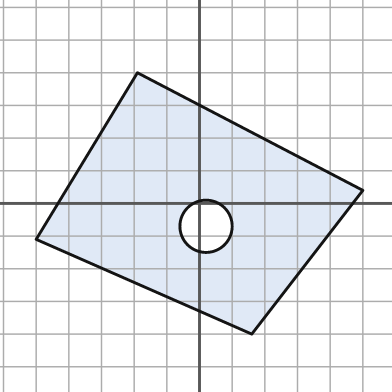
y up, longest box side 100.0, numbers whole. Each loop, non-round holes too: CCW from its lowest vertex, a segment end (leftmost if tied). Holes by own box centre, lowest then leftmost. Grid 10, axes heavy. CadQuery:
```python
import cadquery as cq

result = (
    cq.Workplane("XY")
    .moveTo(16.0, -40.0)
    .lineTo(50.0, 4.0)
    .lineTo(-19.0, 40.0)
    .lineTo(-50.0, -11.0)
    .close()
    .moveTo(2.0, -7.0)
    .circle(8.0)
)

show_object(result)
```